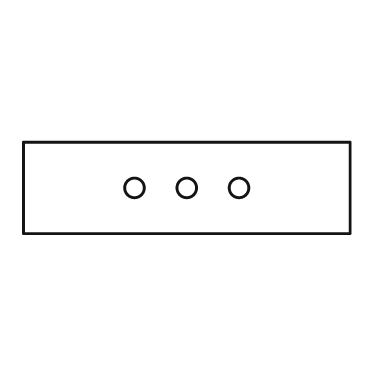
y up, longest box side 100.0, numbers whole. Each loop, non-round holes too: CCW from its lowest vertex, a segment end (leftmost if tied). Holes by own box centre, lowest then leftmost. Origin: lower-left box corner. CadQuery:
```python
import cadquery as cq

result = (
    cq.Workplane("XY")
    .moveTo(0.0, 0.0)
    .lineTo(100.0, 0.0)
    .lineTo(100.0, 28.0)
    .lineTo(0.0, 28.0)
    .close()
    .moveTo(34.0, 14.0)
    .circle(3.0)
    .moveTo(50.0, 14.0)
    .circle(3.0)
    .moveTo(66.0, 14.0)
    .circle(3.0)
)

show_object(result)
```